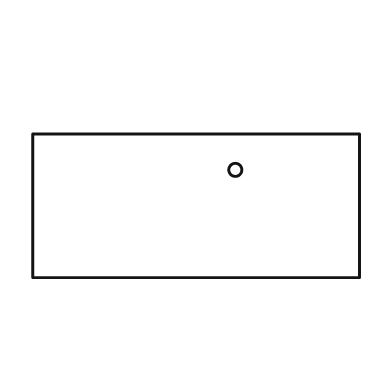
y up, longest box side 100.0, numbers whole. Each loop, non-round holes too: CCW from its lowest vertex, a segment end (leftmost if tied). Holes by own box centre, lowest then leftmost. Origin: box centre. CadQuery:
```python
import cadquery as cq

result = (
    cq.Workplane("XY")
    .moveTo(-50.0, -22.0)
    .lineTo(50.0, -22.0)
    .lineTo(50.0, 22.0)
    .lineTo(-50.0, 22.0)
    .close()
    .moveTo(12.0, 11.0)
    .circle(2.0)
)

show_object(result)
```